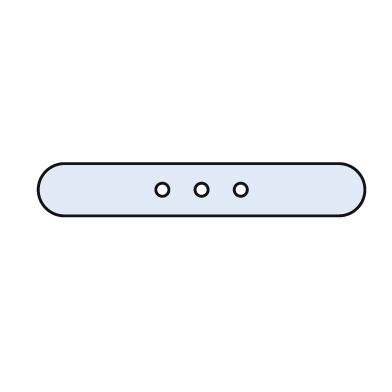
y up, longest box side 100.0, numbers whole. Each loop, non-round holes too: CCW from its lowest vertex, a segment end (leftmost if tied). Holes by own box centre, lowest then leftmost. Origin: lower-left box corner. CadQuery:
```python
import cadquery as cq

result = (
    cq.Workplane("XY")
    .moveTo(8.0, 0.0)
    .lineTo(92.0, 0.0)
    .threePointArc((100.0, 8.0), (92.0, 16.0))
    .lineTo(8.0, 16.0)
    .threePointArc((0.0, 8.0), (8.0, 0.0))
    .close()
    .moveTo(38.0, 8.0)
    .circle(2.0)
    .moveTo(50.0, 8.0)
    .circle(2.0)
    .moveTo(62.0, 8.0)
    .circle(2.0)
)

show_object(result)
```